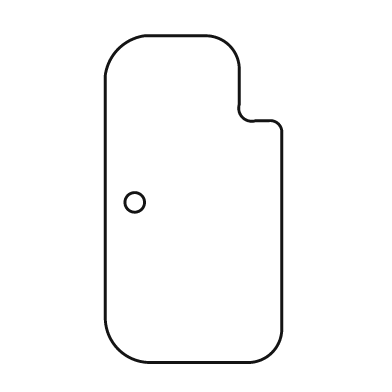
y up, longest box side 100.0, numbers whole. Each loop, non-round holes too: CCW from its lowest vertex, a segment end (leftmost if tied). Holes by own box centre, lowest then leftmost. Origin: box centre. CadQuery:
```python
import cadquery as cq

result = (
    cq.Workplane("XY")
    .moveTo(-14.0, -50.0)
    .lineTo(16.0, -50.0)
    .threePointArc((24.0, -47.0), (27.0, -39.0))
    .lineTo(27.0, 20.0)
    .threePointArc((26.0, 23.0), (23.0, 24.0))
    .lineTo(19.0, 24.0)
    .threePointArc((15.0, 25.0), (14.0, 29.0))
    .lineTo(14.0, 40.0)
    .threePointArc((11.0, 47.0), (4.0, 50.0))
    .lineTo(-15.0, 50.0)
    .threePointArc((-23.0, 46.0), (-27.0, 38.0))
    .lineTo(-27.0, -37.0)
    .threePointArc((-23.0, -46.0), (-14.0, -50.0))
    .close()
    .moveTo(-18.0, -1.0)
    .circle(3.0)
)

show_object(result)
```